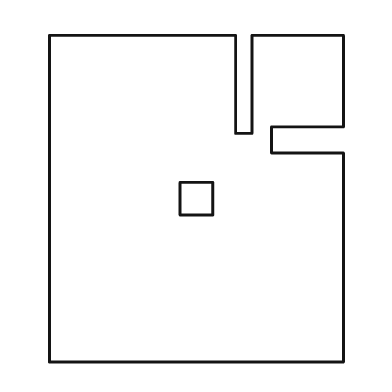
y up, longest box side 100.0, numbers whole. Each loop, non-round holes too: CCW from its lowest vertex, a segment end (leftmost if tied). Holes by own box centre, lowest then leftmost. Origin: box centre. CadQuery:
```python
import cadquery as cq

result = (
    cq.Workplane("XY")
    .moveTo(-45.0, -50.0)
    .lineTo(45.0, -50.0)
    .lineTo(45.0, 14.0)
    .lineTo(23.0, 14.0)
    .lineTo(23.0, 22.0)
    .lineTo(45.0, 22.0)
    .lineTo(45.0, 50.0)
    .lineTo(17.0, 50.0)
    .lineTo(17.0, 20.0)
    .lineTo(12.0, 20.0)
    .lineTo(12.0, 50.0)
    .lineTo(-45.0, 50.0)
    .close()
    .moveTo(-5.0, -5.0)
    .lineTo(5.0, -5.0)
    .lineTo(5.0, 5.0)
    .lineTo(-5.0, 5.0)
    .close()
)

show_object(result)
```